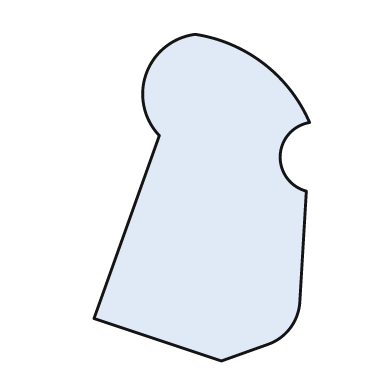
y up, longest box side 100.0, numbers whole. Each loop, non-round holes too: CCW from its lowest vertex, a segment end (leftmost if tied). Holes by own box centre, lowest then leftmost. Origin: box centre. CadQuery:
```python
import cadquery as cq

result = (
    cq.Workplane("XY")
    .moveTo(6.0, -50.0)
    .lineTo(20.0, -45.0)
    .threePointArc((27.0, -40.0), (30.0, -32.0))
    .lineTo(32.0, 2.0)
    .threePointArc((24.0, 13.0), (33.0, 23.0))
    .threePointArc((19.0, 41.0), (-2.0, 50.0))
    .threePointArc((-17.0, 38.0), (-13.0, 19.0))
    .lineTo(-33.0, -37.0)
    .close()
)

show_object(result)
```